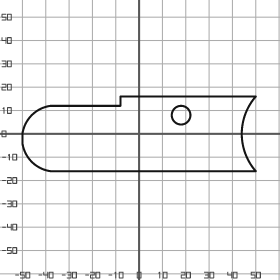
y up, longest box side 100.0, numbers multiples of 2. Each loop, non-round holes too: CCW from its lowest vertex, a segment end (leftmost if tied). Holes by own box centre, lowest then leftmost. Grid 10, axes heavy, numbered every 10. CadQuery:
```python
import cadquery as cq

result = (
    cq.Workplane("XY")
    .moveTo(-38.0, -16.0)
    .lineTo(50.0, -16.0)
    .threePointArc((44.0, 0.0), (50.0, 16.0))
    .lineTo(-8.0, 16.0)
    .lineTo(-8.0, 12.0)
    .lineTo(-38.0, 12.0)
    .threePointArc((-46.0, 8.0), (-50.0, 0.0))
    .lineTo(-50.0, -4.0)
    .threePointArc((-46.0, -12.0), (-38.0, -16.0))
    .close()
    .moveTo(18.0, 8.0)
    .circle(4.0)
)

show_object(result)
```